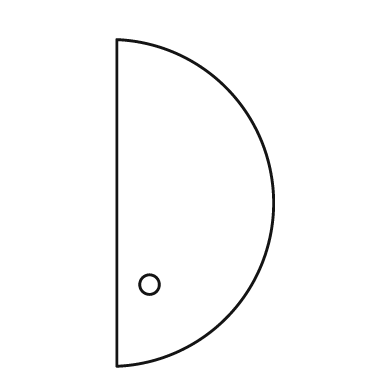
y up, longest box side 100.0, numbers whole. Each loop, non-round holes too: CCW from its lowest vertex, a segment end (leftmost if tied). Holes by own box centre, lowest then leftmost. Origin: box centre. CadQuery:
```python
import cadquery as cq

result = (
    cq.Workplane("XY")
    .moveTo(-24.0, -50.0)
    .threePointArc((24.0, 0.0), (-24.0, 50.0))
    .close()
    .moveTo(-14.0, -25.0)
    .circle(3.0)
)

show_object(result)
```